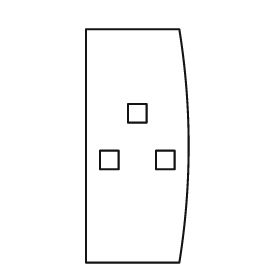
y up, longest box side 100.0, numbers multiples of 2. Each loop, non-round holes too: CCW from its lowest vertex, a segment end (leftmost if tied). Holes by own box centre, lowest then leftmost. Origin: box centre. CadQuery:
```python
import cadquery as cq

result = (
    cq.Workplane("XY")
    .moveTo(-22.0, -50.0)
    .lineTo(18.0, -50.0)
    .threePointArc((22.0, 0.0), (18.0, 50.0))
    .lineTo(-22.0, 50.0)
    .close()
    .moveTo(-16.0, -10.0)
    .lineTo(-8.0, -10.0)
    .lineTo(-8.0, -2.0)
    .lineTo(-16.0, -2.0)
    .close()
    .moveTo(8.0, -10.0)
    .lineTo(16.0, -10.0)
    .lineTo(16.0, -2.0)
    .lineTo(8.0, -2.0)
    .close()
    .moveTo(-4.0, 10.0)
    .lineTo(4.0, 10.0)
    .lineTo(4.0, 18.0)
    .lineTo(-4.0, 18.0)
    .close()
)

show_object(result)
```